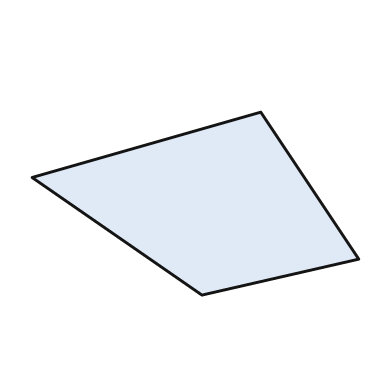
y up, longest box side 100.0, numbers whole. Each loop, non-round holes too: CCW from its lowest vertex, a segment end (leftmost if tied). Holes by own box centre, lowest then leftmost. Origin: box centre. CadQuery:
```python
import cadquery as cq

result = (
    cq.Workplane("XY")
    .moveTo(2.0, -28.0)
    .lineTo(50.0, -17.0)
    .lineTo(20.0, 28.0)
    .lineTo(-50.0, 8.0)
    .close()
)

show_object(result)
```